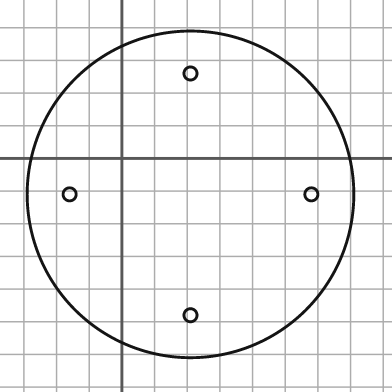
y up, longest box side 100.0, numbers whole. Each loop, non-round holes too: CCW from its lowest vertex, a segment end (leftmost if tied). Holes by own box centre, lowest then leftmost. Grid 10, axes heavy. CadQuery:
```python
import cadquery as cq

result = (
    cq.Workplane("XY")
    .moveTo(21.0, -11.0)
    .circle(50.0)
    .moveTo(21.0, -48.0)
    .circle(2.0)
    .moveTo(-16.0, -11.0)
    .circle(2.0)
    .moveTo(58.0, -11.0)
    .circle(2.0)
    .moveTo(21.0, 26.0)
    .circle(2.0)
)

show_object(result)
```